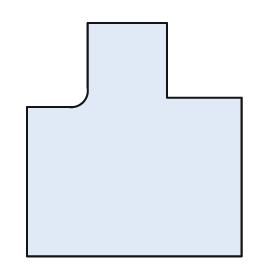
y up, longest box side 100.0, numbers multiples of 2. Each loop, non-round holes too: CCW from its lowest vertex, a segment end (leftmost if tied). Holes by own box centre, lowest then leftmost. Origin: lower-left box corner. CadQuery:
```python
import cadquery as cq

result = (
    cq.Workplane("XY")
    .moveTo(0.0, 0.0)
    .lineTo(92.0, 0.0)
    .lineTo(92.0, 68.0)
    .lineTo(60.0, 68.0)
    .lineTo(60.0, 100.0)
    .lineTo(26.0, 100.0)
    .lineTo(26.0, 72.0)
    .threePointArc((24.0, 66.0), (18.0, 64.0))
    .lineTo(0.0, 64.0)
    .close()
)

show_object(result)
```